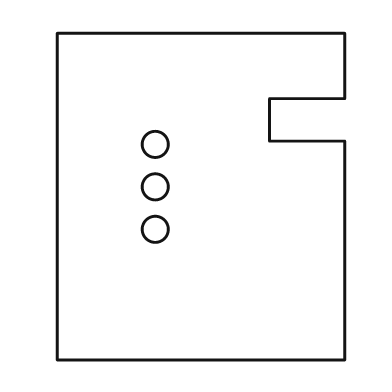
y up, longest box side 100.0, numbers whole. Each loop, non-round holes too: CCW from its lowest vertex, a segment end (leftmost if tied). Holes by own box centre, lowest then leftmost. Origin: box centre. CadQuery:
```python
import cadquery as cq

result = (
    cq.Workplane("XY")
    .moveTo(-44.0, -50.0)
    .lineTo(44.0, -50.0)
    .lineTo(44.0, 17.0)
    .lineTo(21.0, 17.0)
    .lineTo(21.0, 30.0)
    .lineTo(44.0, 30.0)
    .lineTo(44.0, 50.0)
    .lineTo(-44.0, 50.0)
    .close()
    .moveTo(-14.0, -10.0)
    .circle(4.0)
    .moveTo(-14.0, 3.0)
    .circle(4.0)
    .moveTo(-14.0, 16.0)
    .circle(4.0)
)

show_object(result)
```